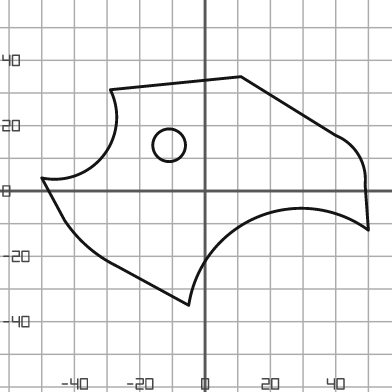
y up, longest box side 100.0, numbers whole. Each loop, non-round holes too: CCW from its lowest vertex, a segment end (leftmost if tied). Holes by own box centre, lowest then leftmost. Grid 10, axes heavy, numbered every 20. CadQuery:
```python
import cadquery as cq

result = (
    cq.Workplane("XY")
    .moveTo(-5.0, -35.0)
    .threePointArc((16.0, -8.0), (50.0, -12.0))
    .lineTo(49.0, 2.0)
    .threePointArc((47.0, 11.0), (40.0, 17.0))
    .lineTo(11.0, 35.0)
    .lineTo(-29.0, 31.0)
    .threePointArc((-31.0, 11.0), (-50.0, 4.0))
    .lineTo(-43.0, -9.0)
    .threePointArc((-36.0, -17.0), (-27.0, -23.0))
    .close()
    .moveTo(-11.0, 14.0)
    .circle(5.0)
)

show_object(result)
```